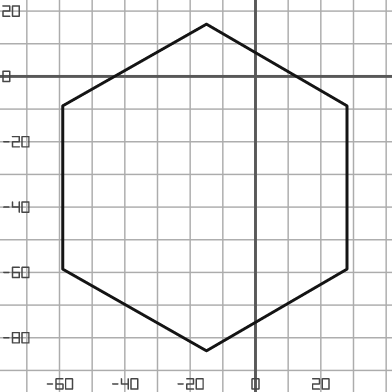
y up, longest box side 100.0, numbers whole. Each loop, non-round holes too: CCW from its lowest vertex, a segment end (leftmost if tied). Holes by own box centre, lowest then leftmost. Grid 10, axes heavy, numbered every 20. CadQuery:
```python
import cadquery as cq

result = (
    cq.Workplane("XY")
    .moveTo(-15.0, -84.0)
    .lineTo(28.0, -59.0)
    .lineTo(28.0, -9.0)
    .lineTo(-15.0, 16.0)
    .lineTo(-59.0, -9.0)
    .lineTo(-59.0, -59.0)
    .close()
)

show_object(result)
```